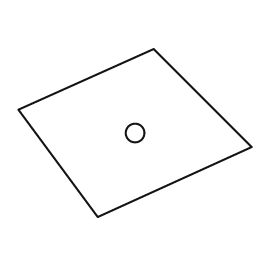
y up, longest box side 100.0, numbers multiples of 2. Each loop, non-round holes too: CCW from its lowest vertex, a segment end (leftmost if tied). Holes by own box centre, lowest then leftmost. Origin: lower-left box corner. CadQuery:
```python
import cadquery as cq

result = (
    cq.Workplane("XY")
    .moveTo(34.0, 0.0)
    .lineTo(100.0, 30.0)
    .lineTo(58.0, 72.0)
    .lineTo(0.0, 46.0)
    .close()
    .moveTo(50.0, 36.0)
    .circle(4.0)
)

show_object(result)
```